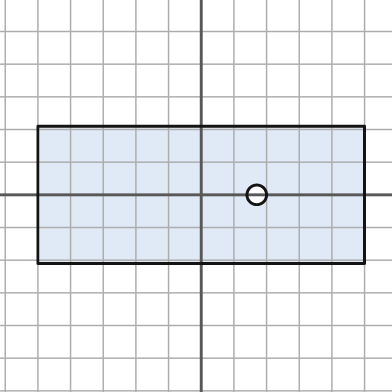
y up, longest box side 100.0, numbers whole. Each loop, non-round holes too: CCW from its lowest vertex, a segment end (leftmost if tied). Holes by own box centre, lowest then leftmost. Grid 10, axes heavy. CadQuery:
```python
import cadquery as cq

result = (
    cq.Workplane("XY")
    .moveTo(-50.0, -21.0)
    .lineTo(50.0, -21.0)
    .lineTo(50.0, 21.0)
    .lineTo(-50.0, 21.0)
    .close()
    .moveTo(17.0, 0.0)
    .circle(3.0)
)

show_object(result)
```